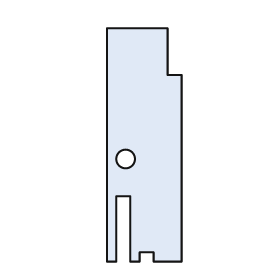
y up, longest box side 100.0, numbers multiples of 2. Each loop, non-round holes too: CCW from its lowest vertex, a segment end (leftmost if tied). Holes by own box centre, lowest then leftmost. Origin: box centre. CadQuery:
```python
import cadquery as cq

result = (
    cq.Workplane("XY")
    .moveTo(-16.0, -50.0)
    .lineTo(-12.0, -50.0)
    .lineTo(-12.0, -22.0)
    .lineTo(-6.0, -22.0)
    .lineTo(-6.0, -50.0)
    .lineTo(-2.0, -50.0)
    .lineTo(-2.0, -46.0)
    .lineTo(4.0, -46.0)
    .lineTo(4.0, -50.0)
    .lineTo(16.0, -50.0)
    .lineTo(16.0, 30.0)
    .lineTo(10.0, 30.0)
    .lineTo(10.0, 50.0)
    .lineTo(-16.0, 50.0)
    .close()
    .moveTo(-8.0, -6.0)
    .circle(4.0)
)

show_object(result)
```